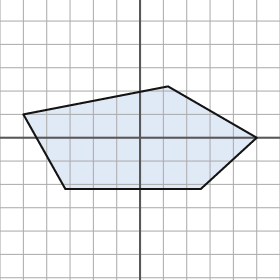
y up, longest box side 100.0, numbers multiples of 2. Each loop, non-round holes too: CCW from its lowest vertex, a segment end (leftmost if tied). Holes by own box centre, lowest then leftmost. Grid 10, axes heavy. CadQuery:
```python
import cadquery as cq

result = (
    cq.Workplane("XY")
    .moveTo(-32.0, -22.0)
    .lineTo(26.0, -22.0)
    .lineTo(50.0, 0.0)
    .lineTo(12.0, 22.0)
    .lineTo(-50.0, 10.0)
    .close()
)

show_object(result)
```